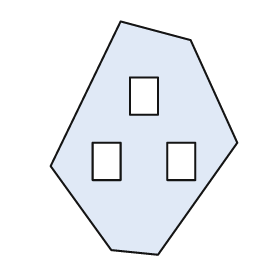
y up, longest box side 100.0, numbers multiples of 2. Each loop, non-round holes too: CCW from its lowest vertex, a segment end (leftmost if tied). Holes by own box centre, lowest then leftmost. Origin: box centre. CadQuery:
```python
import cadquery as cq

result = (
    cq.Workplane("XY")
    .moveTo(6.0, -50.0)
    .lineTo(40.0, -2.0)
    .lineTo(20.0, 42.0)
    .lineTo(-10.0, 50.0)
    .lineTo(-40.0, -12.0)
    .lineTo(-14.0, -48.0)
    .close()
    .moveTo(-22.0, -18.0)
    .lineTo(-10.0, -18.0)
    .lineTo(-10.0, -2.0)
    .lineTo(-22.0, -2.0)
    .close()
    .moveTo(10.0, -18.0)
    .lineTo(22.0, -18.0)
    .lineTo(22.0, -2.0)
    .lineTo(10.0, -2.0)
    .close()
    .moveTo(-6.0, 10.0)
    .lineTo(6.0, 10.0)
    .lineTo(6.0, 26.0)
    .lineTo(-6.0, 26.0)
    .close()
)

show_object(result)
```